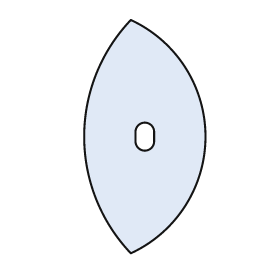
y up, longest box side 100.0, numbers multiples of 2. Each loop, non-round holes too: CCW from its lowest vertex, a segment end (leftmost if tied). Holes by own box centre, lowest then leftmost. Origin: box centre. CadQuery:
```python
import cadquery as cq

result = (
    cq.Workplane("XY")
    .moveTo(-6.0, -50.0)
    .threePointArc((26.0, 0.0), (-6.0, 50.0))
    .threePointArc((-26.0, 0.0), (-6.0, -50.0))
    .close()
    .moveTo(-4.0, -2.0)
    .threePointArc((0.0, -6.0), (4.0, -2.0))
    .lineTo(4.0, 2.0)
    .threePointArc((0.0, 6.0), (-4.0, 2.0))
    .close()
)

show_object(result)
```